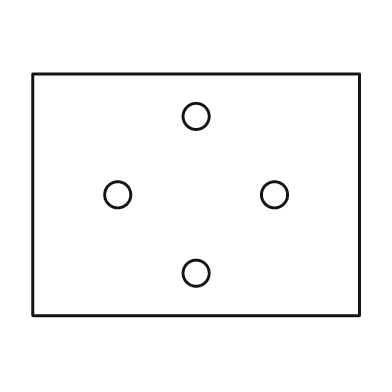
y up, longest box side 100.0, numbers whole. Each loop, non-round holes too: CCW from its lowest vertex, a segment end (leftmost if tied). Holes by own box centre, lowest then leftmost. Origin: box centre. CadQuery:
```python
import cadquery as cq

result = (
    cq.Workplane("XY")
    .moveTo(-50.0, -37.0)
    .lineTo(50.0, -37.0)
    .lineTo(50.0, 37.0)
    .lineTo(-50.0, 37.0)
    .close()
    .moveTo(0.0, -24.0)
    .circle(4.0)
    .moveTo(-24.0, 0.0)
    .circle(4.0)
    .moveTo(24.0, 0.0)
    .circle(4.0)
    .moveTo(0.0, 24.0)
    .circle(4.0)
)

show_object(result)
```